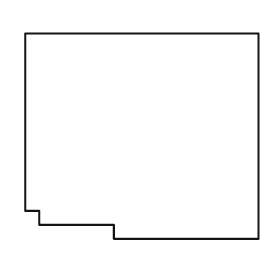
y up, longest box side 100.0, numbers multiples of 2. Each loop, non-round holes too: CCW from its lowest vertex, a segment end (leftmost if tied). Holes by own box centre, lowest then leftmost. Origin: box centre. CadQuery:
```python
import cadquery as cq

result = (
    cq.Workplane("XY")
    .moveTo(-12.0, -44.0)
    .lineTo(50.0, -44.0)
    .lineTo(50.0, 44.0)
    .lineTo(-50.0, 44.0)
    .lineTo(-50.0, -32.0)
    .lineTo(-44.0, -32.0)
    .lineTo(-44.0, -38.0)
    .lineTo(-12.0, -38.0)
    .close()
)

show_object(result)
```